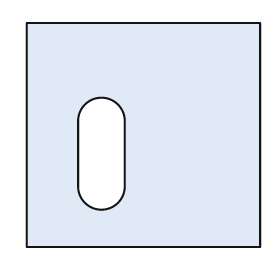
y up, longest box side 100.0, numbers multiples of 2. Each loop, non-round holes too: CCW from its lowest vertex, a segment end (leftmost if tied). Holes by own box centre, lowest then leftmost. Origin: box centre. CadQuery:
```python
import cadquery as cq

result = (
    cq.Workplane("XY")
    .moveTo(-50.0, -48.0)
    .lineTo(50.0, -48.0)
    .lineTo(50.0, 48.0)
    .lineTo(-50.0, 48.0)
    .close()
    .moveTo(-28.0, -22.0)
    .threePointArc((-18.0, -32.0), (-8.0, -22.0))
    .lineTo(-8.0, 6.0)
    .threePointArc((-18.0, 16.0), (-28.0, 6.0))
    .close()
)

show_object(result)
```